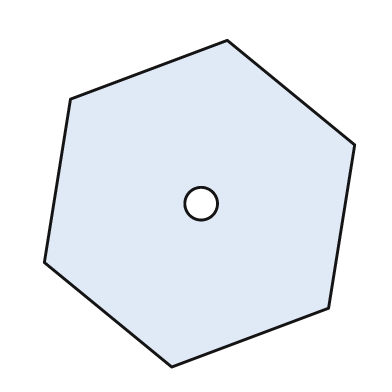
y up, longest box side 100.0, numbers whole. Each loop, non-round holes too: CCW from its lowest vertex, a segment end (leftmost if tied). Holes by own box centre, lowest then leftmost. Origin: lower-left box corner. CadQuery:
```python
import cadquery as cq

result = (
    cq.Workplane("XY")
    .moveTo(39.0, 0.0)
    .lineTo(87.0, 18.0)
    .lineTo(95.0, 68.0)
    .lineTo(56.0, 100.0)
    .lineTo(8.0, 82.0)
    .lineTo(0.0, 32.0)
    .close()
    .moveTo(48.0, 50.0)
    .circle(5.0)
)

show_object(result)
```